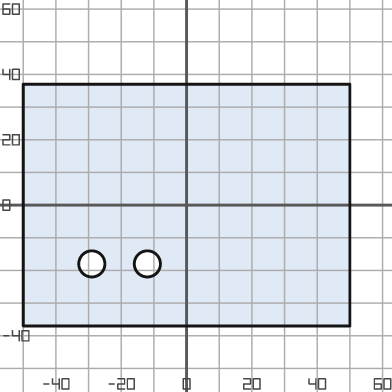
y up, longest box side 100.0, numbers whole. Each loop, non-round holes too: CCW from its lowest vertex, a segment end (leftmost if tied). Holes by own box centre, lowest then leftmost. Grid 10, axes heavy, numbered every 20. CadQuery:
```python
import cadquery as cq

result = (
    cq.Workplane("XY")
    .moveTo(-50.0, -37.0)
    .lineTo(50.0, -37.0)
    .lineTo(50.0, 37.0)
    .lineTo(-50.0, 37.0)
    .close()
    .moveTo(-29.0, -18.0)
    .circle(4.0)
    .moveTo(-12.0, -18.0)
    .circle(4.0)
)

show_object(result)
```